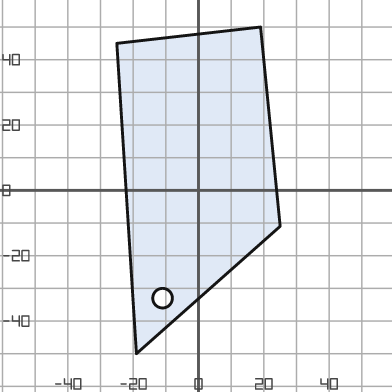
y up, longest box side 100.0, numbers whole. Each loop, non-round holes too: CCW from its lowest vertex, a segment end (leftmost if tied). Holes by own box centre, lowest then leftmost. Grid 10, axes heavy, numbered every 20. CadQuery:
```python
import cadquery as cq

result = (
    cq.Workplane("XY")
    .moveTo(-19.0, -50.0)
    .lineTo(25.0, -11.0)
    .lineTo(19.0, 50.0)
    .lineTo(-25.0, 45.0)
    .close()
    .moveTo(-11.0, -33.0)
    .circle(3.0)
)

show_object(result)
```